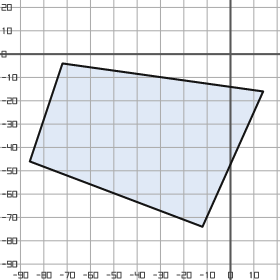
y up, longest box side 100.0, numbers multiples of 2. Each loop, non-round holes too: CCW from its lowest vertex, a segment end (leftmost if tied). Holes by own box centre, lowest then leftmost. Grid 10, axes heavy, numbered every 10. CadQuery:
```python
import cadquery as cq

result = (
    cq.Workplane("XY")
    .moveTo(-12.0, -74.0)
    .lineTo(14.0, -16.0)
    .lineTo(-72.0, -4.0)
    .lineTo(-86.0, -46.0)
    .close()
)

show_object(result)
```